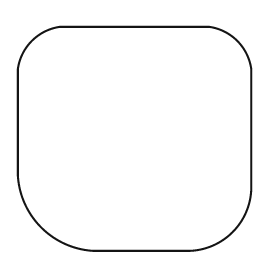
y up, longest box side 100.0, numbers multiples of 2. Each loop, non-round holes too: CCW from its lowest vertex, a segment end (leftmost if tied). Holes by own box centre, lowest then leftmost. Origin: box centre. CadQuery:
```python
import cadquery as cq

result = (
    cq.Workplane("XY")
    .moveTo(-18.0, -48.0)
    .lineTo(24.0, -48.0)
    .threePointArc((42.0, -40.0), (50.0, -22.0))
    .lineTo(50.0, 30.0)
    .threePointArc((44.0, 42.0), (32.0, 48.0))
    .lineTo(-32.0, 48.0)
    .threePointArc((-44.0, 42.0), (-50.0, 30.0))
    .lineTo(-50.0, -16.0)
    .threePointArc((-40.0, -38.0), (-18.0, -48.0))
    .close()
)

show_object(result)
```